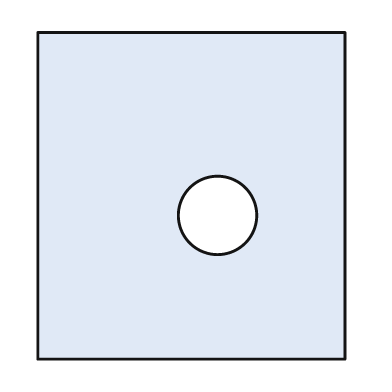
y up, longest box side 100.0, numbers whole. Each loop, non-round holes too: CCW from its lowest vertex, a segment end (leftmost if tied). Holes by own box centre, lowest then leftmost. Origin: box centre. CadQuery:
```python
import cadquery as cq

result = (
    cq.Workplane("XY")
    .moveTo(-47.0, -50.0)
    .lineTo(47.0, -50.0)
    .lineTo(47.0, 50.0)
    .lineTo(-47.0, 50.0)
    .close()
    .moveTo(8.0, -6.0)
    .circle(12.0)
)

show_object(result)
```